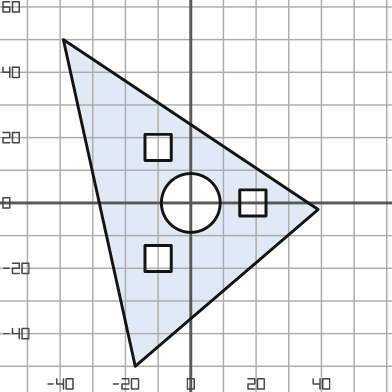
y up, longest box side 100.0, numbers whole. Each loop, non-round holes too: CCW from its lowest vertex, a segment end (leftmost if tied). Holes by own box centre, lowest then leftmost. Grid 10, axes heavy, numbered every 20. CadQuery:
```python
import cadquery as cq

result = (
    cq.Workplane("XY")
    .moveTo(-17.0, -50.0)
    .lineTo(39.0, -2.0)
    .lineTo(-39.0, 50.0)
    .close()
    .moveTo(-14.0, -21.0)
    .lineTo(-6.0, -21.0)
    .lineTo(-6.0, -13.0)
    .lineTo(-14.0, -13.0)
    .close()
    .moveTo(0.0, 0.0)
    .circle(9.0)
    .moveTo(15.0, -4.0)
    .lineTo(23.0, -4.0)
    .lineTo(23.0, 4.0)
    .lineTo(15.0, 4.0)
    .close()
    .moveTo(-14.0, 13.0)
    .lineTo(-6.0, 13.0)
    .lineTo(-6.0, 21.0)
    .lineTo(-14.0, 21.0)
    .close()
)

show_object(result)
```